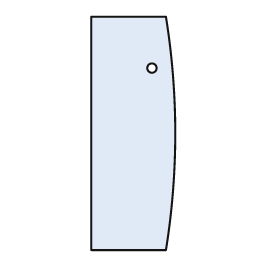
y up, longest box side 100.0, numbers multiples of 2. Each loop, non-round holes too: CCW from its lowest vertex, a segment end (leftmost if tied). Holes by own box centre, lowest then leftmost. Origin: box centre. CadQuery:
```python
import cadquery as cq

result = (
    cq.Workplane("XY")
    .moveTo(-18.0, -50.0)
    .lineTo(14.0, -50.0)
    .threePointArc((18.0, 0.0), (14.0, 50.0))
    .lineTo(-18.0, 50.0)
    .close()
    .moveTo(8.0, 28.0)
    .circle(2.0)
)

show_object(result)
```